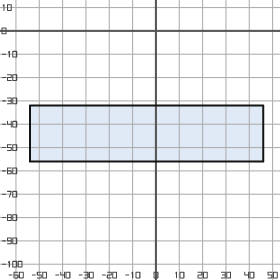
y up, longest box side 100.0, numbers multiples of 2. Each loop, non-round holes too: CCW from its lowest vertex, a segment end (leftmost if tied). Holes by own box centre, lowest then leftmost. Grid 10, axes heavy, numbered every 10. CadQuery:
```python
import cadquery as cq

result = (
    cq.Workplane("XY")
    .moveTo(-54.0, -56.0)
    .lineTo(46.0, -56.0)
    .lineTo(46.0, -32.0)
    .lineTo(-54.0, -32.0)
    .close()
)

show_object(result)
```